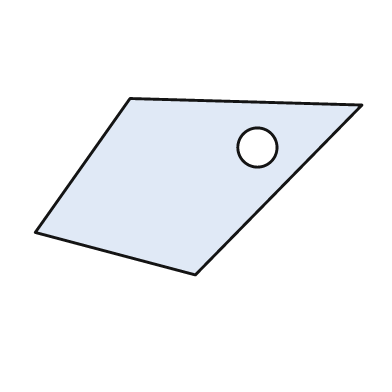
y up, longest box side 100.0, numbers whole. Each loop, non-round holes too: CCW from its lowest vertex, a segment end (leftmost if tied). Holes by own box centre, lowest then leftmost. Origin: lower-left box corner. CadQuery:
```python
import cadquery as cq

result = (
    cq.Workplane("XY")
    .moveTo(49.0, 0.0)
    .lineTo(100.0, 52.0)
    .lineTo(29.0, 54.0)
    .lineTo(0.0, 13.0)
    .close()
    .moveTo(68.0, 39.0)
    .circle(6.0)
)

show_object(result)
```